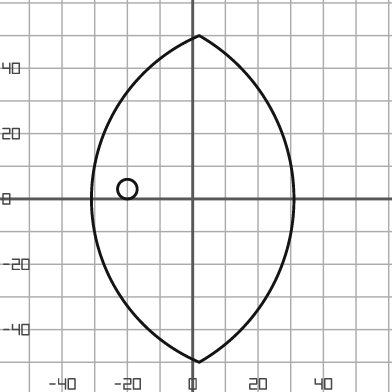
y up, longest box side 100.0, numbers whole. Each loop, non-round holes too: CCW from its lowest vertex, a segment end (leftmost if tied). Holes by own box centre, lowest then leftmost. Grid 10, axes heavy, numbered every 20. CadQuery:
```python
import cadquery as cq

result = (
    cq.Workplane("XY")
    .moveTo(2.0, -50.0)
    .threePointArc((31.0, 0.0), (2.0, 50.0))
    .threePointArc((-31.0, 0.0), (2.0, -50.0))
    .close()
    .moveTo(-20.0, 3.0)
    .circle(3.0)
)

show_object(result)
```